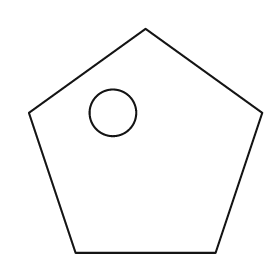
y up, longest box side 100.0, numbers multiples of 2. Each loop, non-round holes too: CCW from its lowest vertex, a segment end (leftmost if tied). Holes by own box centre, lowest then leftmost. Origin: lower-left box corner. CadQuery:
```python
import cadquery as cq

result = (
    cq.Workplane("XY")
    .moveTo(20.0, 0.0)
    .lineTo(80.0, 0.0)
    .lineTo(100.0, 60.0)
    .lineTo(50.0, 96.0)
    .lineTo(0.0, 60.0)
    .close()
    .moveTo(36.0, 60.0)
    .circle(10.0)
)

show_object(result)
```